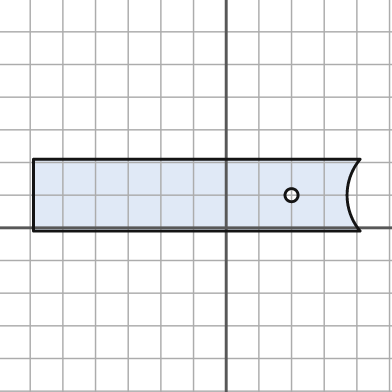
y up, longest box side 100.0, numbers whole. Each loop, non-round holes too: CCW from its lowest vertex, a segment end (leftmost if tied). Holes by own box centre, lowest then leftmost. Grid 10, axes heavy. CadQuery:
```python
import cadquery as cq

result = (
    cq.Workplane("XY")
    .moveTo(-59.0, -1.0)
    .lineTo(41.0, -1.0)
    .threePointArc((37.0, 10.0), (41.0, 21.0))
    .lineTo(-59.0, 21.0)
    .close()
    .moveTo(20.0, 10.0)
    .circle(2.0)
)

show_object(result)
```